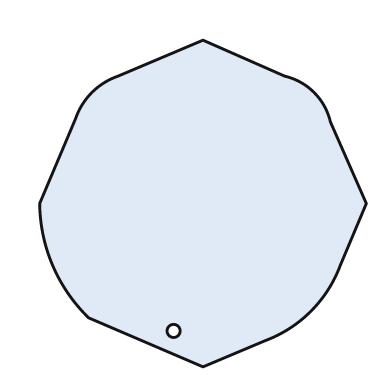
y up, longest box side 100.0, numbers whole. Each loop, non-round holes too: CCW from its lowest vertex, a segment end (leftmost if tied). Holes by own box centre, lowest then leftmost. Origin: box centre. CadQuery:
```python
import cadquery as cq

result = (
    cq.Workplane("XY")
    .moveTo(0.0, -50.0)
    .lineTo(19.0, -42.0)
    .threePointArc((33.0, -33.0), (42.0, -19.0))
    .lineTo(50.0, 0.0)
    .lineTo(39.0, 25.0)
    .threePointArc((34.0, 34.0), (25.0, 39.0))
    .lineTo(0.0, 50.0)
    .lineTo(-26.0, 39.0)
    .threePointArc((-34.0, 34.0), (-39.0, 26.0))
    .lineTo(-50.0, 0.0)
    .threePointArc((-46.0, -19.0), (-35.0, -35.0))
    .close()
    .moveTo(-9.0, -39.0)
    .circle(2.0)
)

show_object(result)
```